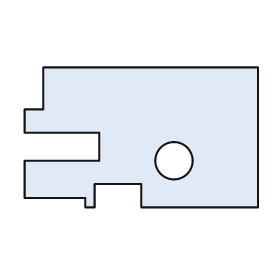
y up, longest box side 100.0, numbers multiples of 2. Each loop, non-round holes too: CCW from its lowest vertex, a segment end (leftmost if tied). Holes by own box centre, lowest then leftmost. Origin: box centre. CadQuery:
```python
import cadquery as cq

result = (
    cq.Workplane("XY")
    .moveTo(-24.0, -30.0)
    .lineTo(-20.0, -30.0)
    .lineTo(-20.0, -20.0)
    .lineTo(0.0, -20.0)
    .lineTo(0.0, -30.0)
    .lineTo(50.0, -30.0)
    .lineTo(50.0, 30.0)
    .lineTo(-42.0, 30.0)
    .lineTo(-42.0, 12.0)
    .lineTo(-50.0, 12.0)
    .lineTo(-50.0, 2.0)
    .lineTo(-18.0, 2.0)
    .lineTo(-18.0, -10.0)
    .lineTo(-50.0, -10.0)
    .lineTo(-50.0, -26.0)
    .lineTo(-24.0, -26.0)
    .close()
    .moveTo(14.0, -10.0)
    .circle(8.0)
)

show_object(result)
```